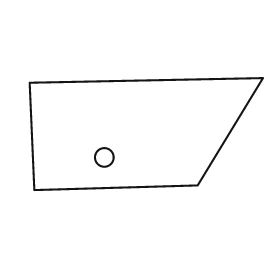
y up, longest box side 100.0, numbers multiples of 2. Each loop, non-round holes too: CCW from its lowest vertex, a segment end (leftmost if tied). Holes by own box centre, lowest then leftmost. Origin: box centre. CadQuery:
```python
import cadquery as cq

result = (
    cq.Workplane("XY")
    .moveTo(-48.0, -24.0)
    .lineTo(22.0, -22.0)
    .lineTo(50.0, 24.0)
    .lineTo(-50.0, 22.0)
    .close()
    .moveTo(-18.0, -10.0)
    .circle(4.0)
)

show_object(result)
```